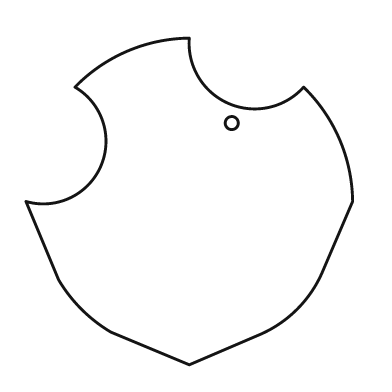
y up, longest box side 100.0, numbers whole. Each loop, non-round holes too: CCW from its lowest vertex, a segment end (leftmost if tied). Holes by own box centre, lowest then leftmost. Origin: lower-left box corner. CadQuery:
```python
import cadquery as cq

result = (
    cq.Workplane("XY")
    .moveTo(50.0, 0.0)
    .lineTo(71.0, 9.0)
    .threePointArc((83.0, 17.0), (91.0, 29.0))
    .lineTo(100.0, 50.0)
    .threePointArc((96.0, 69.0), (85.0, 85.0))
    .threePointArc((62.0, 80.0), (50.0, 100.0))
    .threePointArc((31.0, 96.0), (15.0, 85.0))
    .threePointArc((23.0, 61.0), (0.0, 50.0))
    .lineTo(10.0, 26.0)
    .threePointArc((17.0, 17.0), (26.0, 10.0))
    .close()
    .moveTo(63.0, 74.0)
    .circle(2.0)
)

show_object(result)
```